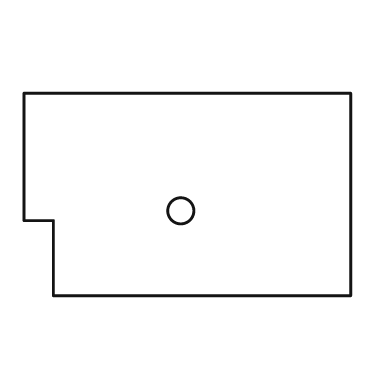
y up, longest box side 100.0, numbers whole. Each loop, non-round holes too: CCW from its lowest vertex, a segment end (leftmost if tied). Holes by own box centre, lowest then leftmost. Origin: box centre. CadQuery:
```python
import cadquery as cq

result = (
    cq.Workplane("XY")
    .moveTo(-41.0, -31.0)
    .lineTo(50.0, -31.0)
    .lineTo(50.0, 31.0)
    .lineTo(-50.0, 31.0)
    .lineTo(-50.0, -8.0)
    .lineTo(-41.0, -8.0)
    .close()
    .moveTo(-2.0, -5.0)
    .circle(4.0)
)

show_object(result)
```